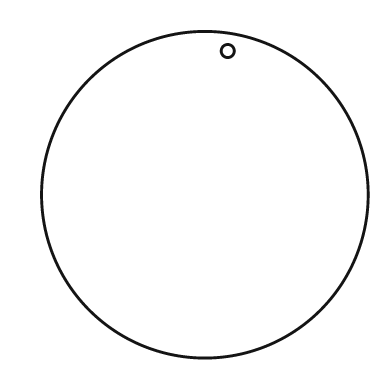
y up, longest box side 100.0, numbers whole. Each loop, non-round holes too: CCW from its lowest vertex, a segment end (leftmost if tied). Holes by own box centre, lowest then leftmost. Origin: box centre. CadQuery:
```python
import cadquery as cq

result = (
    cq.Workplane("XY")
    .moveTo(0.0, 0.0)
    .circle(50.0)
    .moveTo(7.0, 44.0)
    .circle(2.0)
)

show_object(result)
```